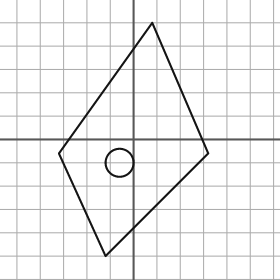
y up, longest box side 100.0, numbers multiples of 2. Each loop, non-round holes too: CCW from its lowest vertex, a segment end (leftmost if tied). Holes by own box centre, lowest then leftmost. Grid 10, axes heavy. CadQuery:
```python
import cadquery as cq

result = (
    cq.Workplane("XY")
    .moveTo(-12.0, -50.0)
    .lineTo(32.0, -6.0)
    .lineTo(8.0, 50.0)
    .lineTo(-32.0, -6.0)
    .close()
    .moveTo(-6.0, -10.0)
    .circle(6.0)
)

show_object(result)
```